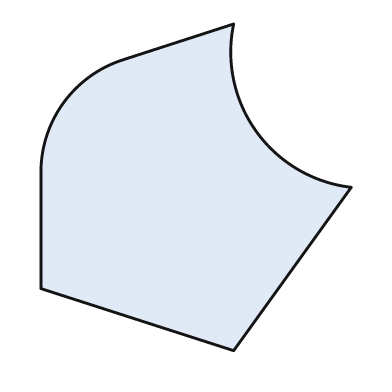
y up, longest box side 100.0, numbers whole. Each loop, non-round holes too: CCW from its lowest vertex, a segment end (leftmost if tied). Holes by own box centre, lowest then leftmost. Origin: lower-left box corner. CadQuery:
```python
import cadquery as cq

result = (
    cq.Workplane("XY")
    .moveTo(59.0, 0.0)
    .lineTo(95.0, 50.0)
    .threePointArc((66.0, 67.0), (59.0, 100.0))
    .lineTo(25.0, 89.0)
    .threePointArc((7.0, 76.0), (0.0, 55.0))
    .lineTo(0.0, 19.0)
    .close()
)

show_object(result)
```